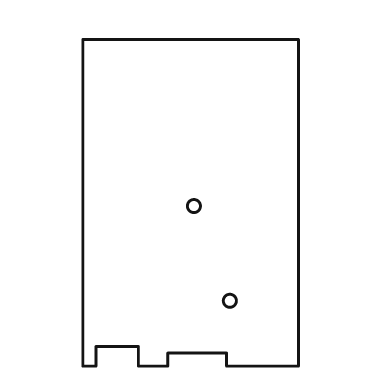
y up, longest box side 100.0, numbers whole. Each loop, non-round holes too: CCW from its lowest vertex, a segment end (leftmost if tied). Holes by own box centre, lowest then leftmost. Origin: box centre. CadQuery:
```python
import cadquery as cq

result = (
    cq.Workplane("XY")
    .moveTo(-33.0, -50.0)
    .lineTo(-29.0, -50.0)
    .lineTo(-29.0, -44.0)
    .lineTo(-16.0, -44.0)
    .lineTo(-16.0, -50.0)
    .lineTo(-7.0, -50.0)
    .lineTo(-7.0, -46.0)
    .lineTo(11.0, -46.0)
    .lineTo(11.0, -50.0)
    .lineTo(33.0, -50.0)
    .lineTo(33.0, 50.0)
    .lineTo(-33.0, 50.0)
    .close()
    .moveTo(12.0, -30.0)
    .circle(2.0)
    .moveTo(1.0, -1.0)
    .circle(2.0)
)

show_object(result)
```